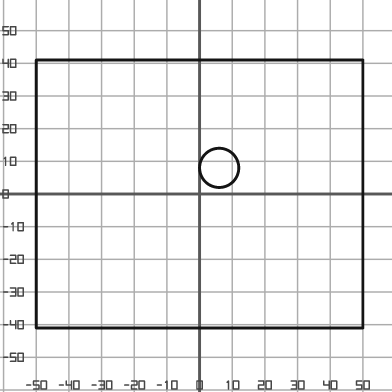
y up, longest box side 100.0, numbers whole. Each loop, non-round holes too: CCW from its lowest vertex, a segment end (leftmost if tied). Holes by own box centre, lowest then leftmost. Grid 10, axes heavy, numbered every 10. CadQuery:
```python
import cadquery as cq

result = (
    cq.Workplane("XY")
    .moveTo(-50.0, -41.0)
    .lineTo(50.0, -41.0)
    .lineTo(50.0, 41.0)
    .lineTo(-50.0, 41.0)
    .close()
    .moveTo(6.0, 8.0)
    .circle(6.0)
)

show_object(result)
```